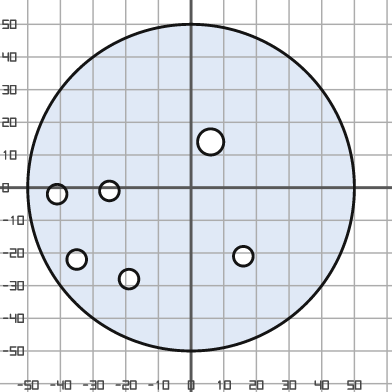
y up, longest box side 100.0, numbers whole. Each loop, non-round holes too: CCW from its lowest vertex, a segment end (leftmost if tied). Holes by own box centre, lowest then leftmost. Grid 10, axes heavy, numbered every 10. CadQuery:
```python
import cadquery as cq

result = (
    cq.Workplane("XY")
    .moveTo(0.0, 0.0)
    .circle(50.0)
    .moveTo(-19.0, -28.0)
    .circle(3.0)
    .moveTo(-35.0, -22.0)
    .circle(3.0)
    .moveTo(16.0, -21.0)
    .circle(3.0)
    .moveTo(-41.0, -2.0)
    .circle(3.0)
    .moveTo(-25.0, -1.0)
    .circle(3.0)
    .moveTo(6.0, 14.0)
    .circle(4.0)
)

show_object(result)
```